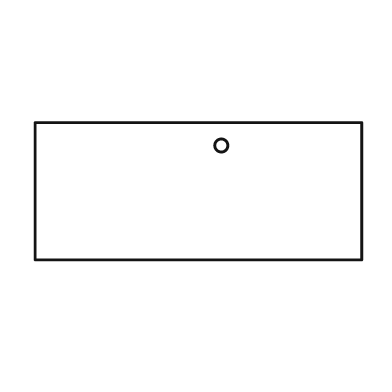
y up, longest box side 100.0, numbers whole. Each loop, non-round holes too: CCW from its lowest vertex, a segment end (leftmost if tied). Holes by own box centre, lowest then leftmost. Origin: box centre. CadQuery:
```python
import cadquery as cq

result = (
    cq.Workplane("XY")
    .moveTo(-50.0, -21.0)
    .lineTo(50.0, -21.0)
    .lineTo(50.0, 21.0)
    .lineTo(-50.0, 21.0)
    .close()
    .moveTo(7.0, 14.0)
    .circle(2.0)
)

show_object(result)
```